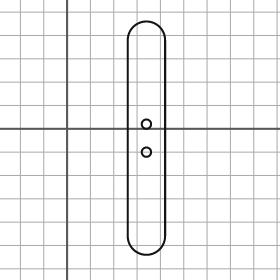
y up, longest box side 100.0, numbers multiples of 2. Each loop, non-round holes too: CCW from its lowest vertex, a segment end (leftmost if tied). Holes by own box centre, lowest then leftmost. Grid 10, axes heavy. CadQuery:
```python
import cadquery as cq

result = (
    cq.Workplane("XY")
    .moveTo(26.0, -46.0)
    .threePointArc((34.0, -54.0), (42.0, -46.0))
    .lineTo(42.0, 38.0)
    .threePointArc((34.0, 46.0), (26.0, 38.0))
    .close()
    .moveTo(34.0, -10.0)
    .circle(2.0)
    .moveTo(34.0, 2.0)
    .circle(2.0)
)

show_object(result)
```